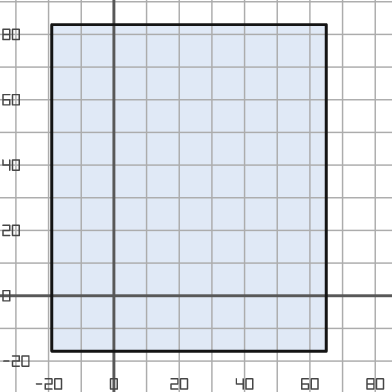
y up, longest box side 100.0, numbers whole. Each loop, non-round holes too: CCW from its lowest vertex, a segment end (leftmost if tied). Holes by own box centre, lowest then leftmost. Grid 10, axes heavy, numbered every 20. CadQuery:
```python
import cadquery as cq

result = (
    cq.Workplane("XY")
    .moveTo(-19.0, -17.0)
    .lineTo(65.0, -17.0)
    .lineTo(65.0, 83.0)
    .lineTo(-19.0, 83.0)
    .close()
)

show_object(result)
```